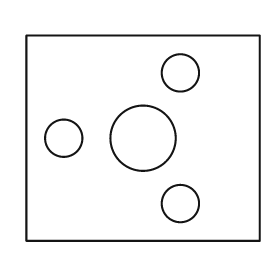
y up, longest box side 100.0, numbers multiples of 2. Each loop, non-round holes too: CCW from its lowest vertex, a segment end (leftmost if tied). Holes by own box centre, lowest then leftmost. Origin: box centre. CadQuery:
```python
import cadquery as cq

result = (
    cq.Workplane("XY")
    .moveTo(-50.0, -44.0)
    .lineTo(50.0, -44.0)
    .lineTo(50.0, 44.0)
    .lineTo(-50.0, 44.0)
    .close()
    .moveTo(16.0, -28.0)
    .circle(8.0)
    .moveTo(-34.0, 0.0)
    .circle(8.0)
    .moveTo(0.0, 0.0)
    .circle(14.0)
    .moveTo(16.0, 28.0)
    .circle(8.0)
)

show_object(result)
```